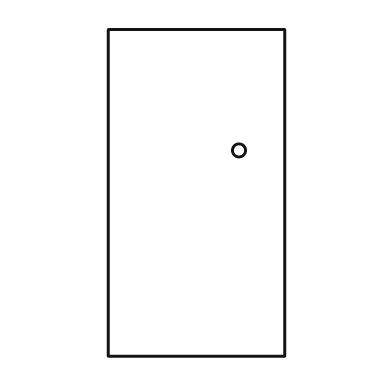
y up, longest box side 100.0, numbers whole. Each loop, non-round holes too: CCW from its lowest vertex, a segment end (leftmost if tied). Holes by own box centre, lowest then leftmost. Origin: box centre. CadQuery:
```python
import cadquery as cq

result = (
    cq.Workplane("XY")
    .moveTo(-27.0, -50.0)
    .lineTo(27.0, -50.0)
    .lineTo(27.0, 50.0)
    .lineTo(-27.0, 50.0)
    .close()
    .moveTo(13.0, 13.0)
    .circle(2.0)
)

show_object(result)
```